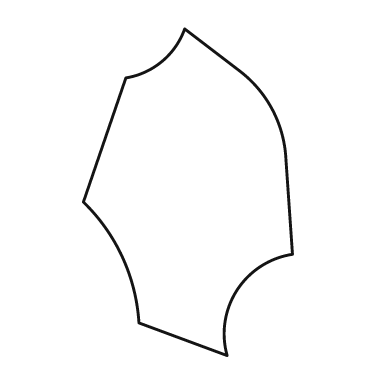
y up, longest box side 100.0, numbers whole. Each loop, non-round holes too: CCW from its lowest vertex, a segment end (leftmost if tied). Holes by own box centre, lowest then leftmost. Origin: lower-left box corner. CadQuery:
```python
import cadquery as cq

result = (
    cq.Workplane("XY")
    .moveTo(44.0, 0.0)
    .threePointArc((47.0, 20.0), (64.0, 31.0))
    .lineTo(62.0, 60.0)
    .threePointArc((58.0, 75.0), (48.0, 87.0))
    .lineTo(31.0, 100.0)
    .threePointArc((24.0, 90.0), (13.0, 85.0))
    .lineTo(0.0, 47.0)
    .threePointArc((12.0, 30.0), (17.0, 10.0))
    .close()
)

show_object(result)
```